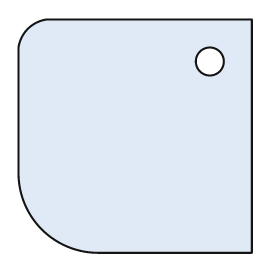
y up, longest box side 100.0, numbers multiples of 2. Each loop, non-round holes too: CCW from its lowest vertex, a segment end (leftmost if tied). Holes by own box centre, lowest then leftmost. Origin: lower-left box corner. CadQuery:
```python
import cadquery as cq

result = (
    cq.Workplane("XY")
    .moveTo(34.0, 0.0)
    .lineTo(100.0, 0.0)
    .lineTo(100.0, 100.0)
    .lineTo(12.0, 100.0)
    .threePointArc((4.0, 96.0), (0.0, 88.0))
    .lineTo(0.0, 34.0)
    .threePointArc((10.0, 10.0), (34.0, 0.0))
    .close()
    .moveTo(82.0, 82.0)
    .circle(6.0)
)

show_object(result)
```